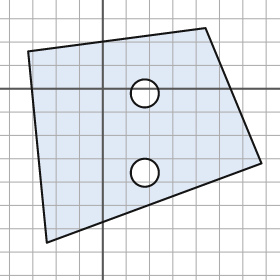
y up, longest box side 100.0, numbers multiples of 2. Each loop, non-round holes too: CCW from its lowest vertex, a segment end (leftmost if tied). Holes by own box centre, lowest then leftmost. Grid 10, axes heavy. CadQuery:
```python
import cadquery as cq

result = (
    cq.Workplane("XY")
    .moveTo(-24.0, -66.0)
    .lineTo(68.0, -32.0)
    .lineTo(44.0, 26.0)
    .lineTo(-32.0, 16.0)
    .close()
    .moveTo(18.0, -36.0)
    .circle(6.0)
    .moveTo(18.0, -2.0)
    .circle(6.0)
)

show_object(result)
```